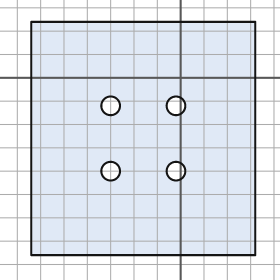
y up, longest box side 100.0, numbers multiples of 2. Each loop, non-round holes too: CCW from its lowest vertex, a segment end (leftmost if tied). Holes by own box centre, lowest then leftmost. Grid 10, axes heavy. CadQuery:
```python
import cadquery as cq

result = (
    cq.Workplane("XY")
    .moveTo(-64.0, -76.0)
    .lineTo(32.0, -76.0)
    .lineTo(32.0, 24.0)
    .lineTo(-64.0, 24.0)
    .close()
    .moveTo(-30.0, -40.0)
    .circle(4.0)
    .moveTo(-2.0, -40.0)
    .circle(4.0)
    .moveTo(-30.0, -12.0)
    .circle(4.0)
    .moveTo(-2.0, -12.0)
    .circle(4.0)
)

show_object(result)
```